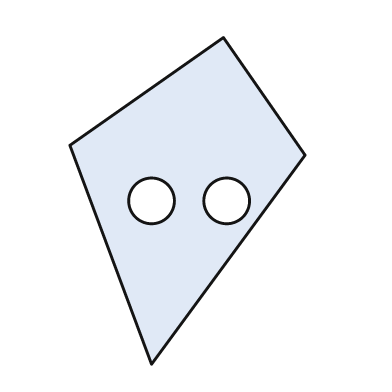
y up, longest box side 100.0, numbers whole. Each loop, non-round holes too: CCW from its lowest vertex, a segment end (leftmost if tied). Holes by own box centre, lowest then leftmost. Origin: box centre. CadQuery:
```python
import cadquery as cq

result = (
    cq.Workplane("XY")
    .moveTo(-11.0, -50.0)
    .lineTo(36.0, 14.0)
    .lineTo(11.0, 50.0)
    .lineTo(-36.0, 17.0)
    .close()
    .moveTo(-11.0, 0.0)
    .circle(7.0)
    .moveTo(12.0, 0.0)
    .circle(7.0)
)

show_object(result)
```